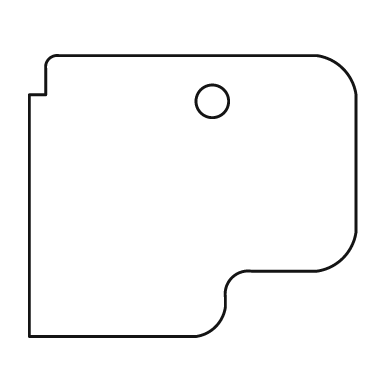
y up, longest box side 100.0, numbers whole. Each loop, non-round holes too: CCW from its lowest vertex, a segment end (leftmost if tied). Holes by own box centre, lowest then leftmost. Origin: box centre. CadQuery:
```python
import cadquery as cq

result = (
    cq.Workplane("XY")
    .moveTo(-50.0, -43.0)
    .lineTo(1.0, -43.0)
    .threePointArc((7.0, -40.0), (10.0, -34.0))
    .lineTo(10.0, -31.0)
    .threePointArc((12.0, -25.0), (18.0, -23.0))
    .lineTo(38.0, -23.0)
    .threePointArc((46.0, -19.0), (50.0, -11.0))
    .lineTo(50.0, 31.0)
    .threePointArc((46.0, 39.0), (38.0, 43.0))
    .lineTo(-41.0, 43.0)
    .threePointArc((-44.0, 42.0), (-45.0, 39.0))
    .lineTo(-45.0, 31.0)
    .lineTo(-50.0, 31.0)
    .close()
    .moveTo(6.0, 29.0)
    .circle(5.0)
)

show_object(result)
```